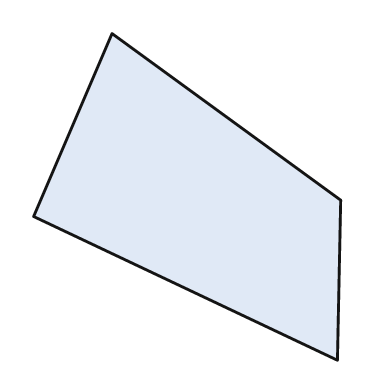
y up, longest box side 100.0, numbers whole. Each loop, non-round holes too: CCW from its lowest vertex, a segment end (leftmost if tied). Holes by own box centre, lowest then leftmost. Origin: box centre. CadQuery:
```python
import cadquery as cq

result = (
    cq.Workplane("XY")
    .moveTo(46.0, -50.0)
    .lineTo(47.0, -1.0)
    .lineTo(-23.0, 50.0)
    .lineTo(-47.0, -6.0)
    .close()
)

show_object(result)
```